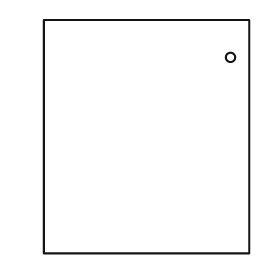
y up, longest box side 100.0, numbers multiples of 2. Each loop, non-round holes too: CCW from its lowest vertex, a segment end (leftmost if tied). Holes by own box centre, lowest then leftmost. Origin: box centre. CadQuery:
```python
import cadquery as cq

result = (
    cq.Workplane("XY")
    .moveTo(-44.0, -50.0)
    .lineTo(44.0, -50.0)
    .lineTo(44.0, 50.0)
    .lineTo(-44.0, 50.0)
    .close()
    .moveTo(36.0, 34.0)
    .circle(2.0)
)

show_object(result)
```